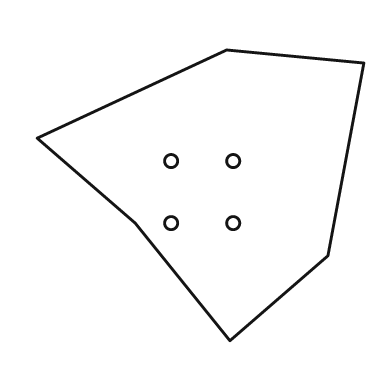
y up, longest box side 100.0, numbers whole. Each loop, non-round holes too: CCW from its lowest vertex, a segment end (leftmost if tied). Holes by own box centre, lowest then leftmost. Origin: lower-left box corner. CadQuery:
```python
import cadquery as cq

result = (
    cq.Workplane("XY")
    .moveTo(59.0, 0.0)
    .lineTo(89.0, 26.0)
    .lineTo(100.0, 85.0)
    .lineTo(58.0, 89.0)
    .lineTo(0.0, 62.0)
    .lineTo(30.0, 36.0)
    .close()
    .moveTo(41.0, 36.0)
    .circle(2.0)
    .moveTo(60.0, 36.0)
    .circle(2.0)
    .moveTo(41.0, 55.0)
    .circle(2.0)
    .moveTo(60.0, 55.0)
    .circle(2.0)
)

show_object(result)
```